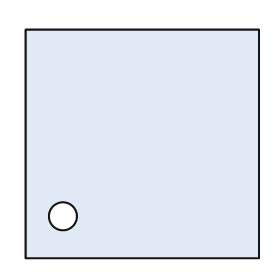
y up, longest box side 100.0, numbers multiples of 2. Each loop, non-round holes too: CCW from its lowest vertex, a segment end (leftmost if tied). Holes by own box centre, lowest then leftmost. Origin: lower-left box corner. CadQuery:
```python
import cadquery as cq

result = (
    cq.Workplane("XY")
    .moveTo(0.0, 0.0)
    .lineTo(100.0, 0.0)
    .lineTo(100.0, 98.0)
    .lineTo(0.0, 98.0)
    .close()
    .moveTo(16.0, 18.0)
    .circle(6.0)
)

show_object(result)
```